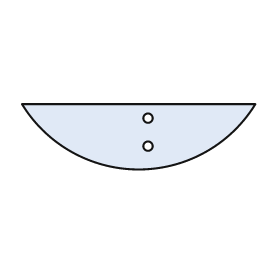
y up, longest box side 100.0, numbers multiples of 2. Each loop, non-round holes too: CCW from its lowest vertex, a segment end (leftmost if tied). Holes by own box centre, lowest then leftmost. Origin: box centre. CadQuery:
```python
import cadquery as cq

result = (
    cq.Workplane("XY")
    .moveTo(-50.0, 14.0)
    .threePointArc((0.0, -14.0), (50.0, 14.0))
    .close()
    .moveTo(4.0, -4.0)
    .circle(2.0)
    .moveTo(4.0, 8.0)
    .circle(2.0)
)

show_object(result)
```